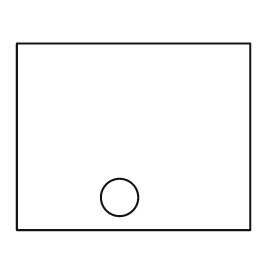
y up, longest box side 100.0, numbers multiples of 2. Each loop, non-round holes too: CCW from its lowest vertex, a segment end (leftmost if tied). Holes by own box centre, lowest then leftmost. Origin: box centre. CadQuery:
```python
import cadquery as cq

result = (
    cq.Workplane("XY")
    .moveTo(-50.0, -40.0)
    .lineTo(50.0, -40.0)
    .lineTo(50.0, 40.0)
    .lineTo(-50.0, 40.0)
    .close()
    .moveTo(-6.0, -26.0)
    .circle(8.0)
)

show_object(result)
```